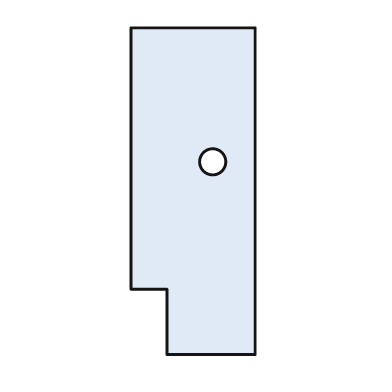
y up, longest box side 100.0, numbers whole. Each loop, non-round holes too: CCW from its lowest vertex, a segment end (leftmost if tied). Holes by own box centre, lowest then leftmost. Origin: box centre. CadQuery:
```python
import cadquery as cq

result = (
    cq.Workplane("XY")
    .moveTo(-8.0, -50.0)
    .lineTo(19.0, -50.0)
    .lineTo(19.0, 50.0)
    .lineTo(-19.0, 50.0)
    .lineTo(-19.0, -30.0)
    .lineTo(-8.0, -30.0)
    .close()
    .moveTo(6.0, 9.0)
    .circle(4.0)
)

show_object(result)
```